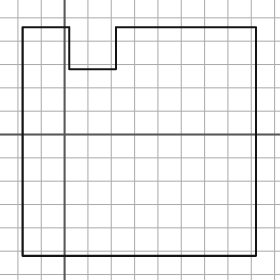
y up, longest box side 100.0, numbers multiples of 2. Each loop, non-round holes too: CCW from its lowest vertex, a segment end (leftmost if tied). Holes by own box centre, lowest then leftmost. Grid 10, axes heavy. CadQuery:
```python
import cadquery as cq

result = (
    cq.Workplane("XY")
    .moveTo(-18.0, -52.0)
    .lineTo(82.0, -52.0)
    .lineTo(82.0, 46.0)
    .lineTo(22.0, 46.0)
    .lineTo(22.0, 28.0)
    .lineTo(2.0, 28.0)
    .lineTo(2.0, 46.0)
    .lineTo(-18.0, 46.0)
    .close()
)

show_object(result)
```